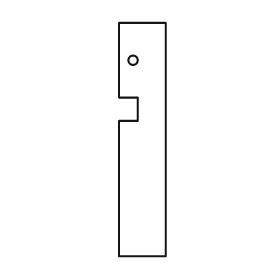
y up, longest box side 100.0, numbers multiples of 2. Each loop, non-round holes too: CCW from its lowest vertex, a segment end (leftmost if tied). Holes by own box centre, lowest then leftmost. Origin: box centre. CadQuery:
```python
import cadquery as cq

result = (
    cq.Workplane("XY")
    .moveTo(-10.0, -50.0)
    .lineTo(10.0, -50.0)
    .lineTo(10.0, 50.0)
    .lineTo(-10.0, 50.0)
    .lineTo(-10.0, 18.0)
    .lineTo(-2.0, 18.0)
    .lineTo(-2.0, 8.0)
    .lineTo(-10.0, 8.0)
    .close()
    .moveTo(-4.0, 34.0)
    .circle(2.0)
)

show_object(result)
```